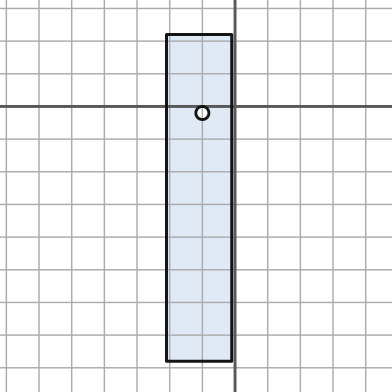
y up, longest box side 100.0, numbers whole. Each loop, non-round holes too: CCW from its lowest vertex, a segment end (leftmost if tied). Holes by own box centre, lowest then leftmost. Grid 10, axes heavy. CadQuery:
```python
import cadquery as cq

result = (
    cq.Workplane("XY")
    .moveTo(-21.0, -78.0)
    .lineTo(-1.0, -78.0)
    .lineTo(-1.0, 22.0)
    .lineTo(-21.0, 22.0)
    .close()
    .moveTo(-10.0, -2.0)
    .circle(2.0)
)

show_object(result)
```